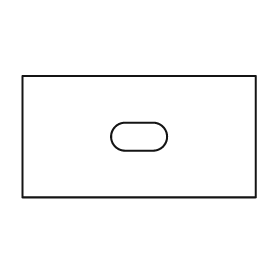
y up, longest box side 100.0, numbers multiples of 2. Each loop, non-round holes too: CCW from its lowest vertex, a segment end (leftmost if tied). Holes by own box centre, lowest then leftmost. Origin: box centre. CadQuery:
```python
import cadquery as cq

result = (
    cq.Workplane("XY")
    .moveTo(-50.0, -26.0)
    .lineTo(50.0, -26.0)
    .lineTo(50.0, 26.0)
    .lineTo(-50.0, 26.0)
    .close()
    .moveTo(-6.0, -6.0)
    .lineTo(6.0, -6.0)
    .threePointArc((12.0, 0.0), (6.0, 6.0))
    .lineTo(-6.0, 6.0)
    .threePointArc((-12.0, 0.0), (-6.0, -6.0))
    .close()
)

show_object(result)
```